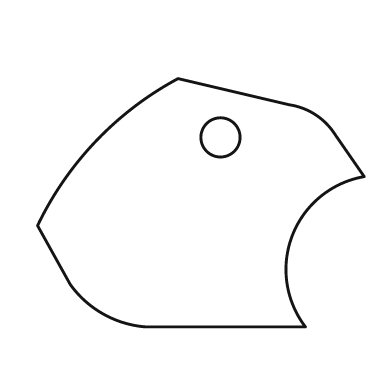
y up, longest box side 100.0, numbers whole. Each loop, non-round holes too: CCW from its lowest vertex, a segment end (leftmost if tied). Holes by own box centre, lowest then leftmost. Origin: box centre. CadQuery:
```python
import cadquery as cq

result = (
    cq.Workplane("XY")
    .moveTo(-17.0, -38.0)
    .lineTo(32.0, -38.0)
    .threePointArc((28.0, -10.0), (50.0, 8.0))
    .lineTo(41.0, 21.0)
    .threePointArc((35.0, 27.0), (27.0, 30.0))
    .lineTo(-7.0, 38.0)
    .threePointArc((-32.0, 19.0), (-50.0, -7.0))
    .lineTo(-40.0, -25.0)
    .threePointArc((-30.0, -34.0), (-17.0, -38.0))
    .close()
    .moveTo(6.0, 20.0)
    .circle(6.0)
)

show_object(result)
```